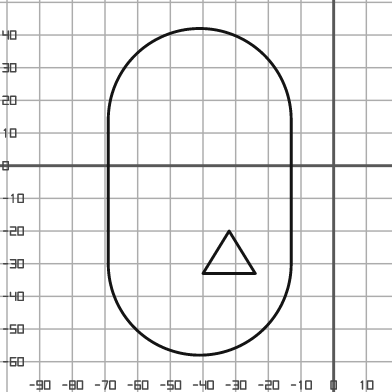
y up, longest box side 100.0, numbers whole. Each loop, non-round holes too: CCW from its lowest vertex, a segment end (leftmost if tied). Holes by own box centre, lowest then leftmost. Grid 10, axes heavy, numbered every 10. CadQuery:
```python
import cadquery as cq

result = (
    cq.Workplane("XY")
    .moveTo(-69.0, -30.0)
    .threePointArc((-41.0, -58.0), (-13.0, -30.0))
    .lineTo(-13.0, 14.0)
    .threePointArc((-41.0, 42.0), (-69.0, 14.0))
    .close()
    .moveTo(-40.0, -33.0)
    .lineTo(-24.0, -33.0)
    .lineTo(-32.0, -20.0)
    .close()
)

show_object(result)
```